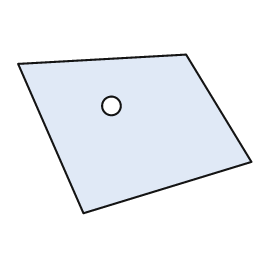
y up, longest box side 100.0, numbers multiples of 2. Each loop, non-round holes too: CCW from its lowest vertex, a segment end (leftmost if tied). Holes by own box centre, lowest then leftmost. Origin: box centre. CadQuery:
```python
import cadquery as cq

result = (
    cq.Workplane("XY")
    .moveTo(-22.0, -34.0)
    .lineTo(50.0, -12.0)
    .lineTo(22.0, 34.0)
    .lineTo(-50.0, 30.0)
    .close()
    .moveTo(-10.0, 12.0)
    .circle(4.0)
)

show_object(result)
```